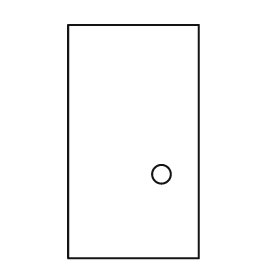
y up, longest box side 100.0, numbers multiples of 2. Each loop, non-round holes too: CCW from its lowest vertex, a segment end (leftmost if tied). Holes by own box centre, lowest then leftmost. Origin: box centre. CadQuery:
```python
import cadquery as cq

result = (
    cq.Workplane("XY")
    .moveTo(-28.0, -50.0)
    .lineTo(28.0, -50.0)
    .lineTo(28.0, 50.0)
    .lineTo(-28.0, 50.0)
    .close()
    .moveTo(12.0, -14.0)
    .circle(4.0)
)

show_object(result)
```